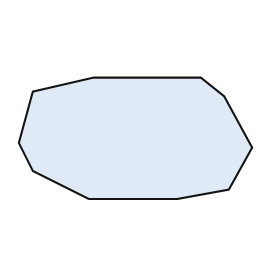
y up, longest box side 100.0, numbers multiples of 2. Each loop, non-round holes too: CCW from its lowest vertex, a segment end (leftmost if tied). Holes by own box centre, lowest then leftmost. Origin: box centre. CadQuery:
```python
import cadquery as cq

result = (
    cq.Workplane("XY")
    .moveTo(-20.0, -26.0)
    .lineTo(18.0, -26.0)
    .lineTo(40.0, -22.0)
    .lineTo(50.0, -4.0)
    .lineTo(38.0, 18.0)
    .lineTo(28.0, 26.0)
    .lineTo(-18.0, 26.0)
    .lineTo(-44.0, 20.0)
    .lineTo(-50.0, -2.0)
    .lineTo(-44.0, -14.0)
    .close()
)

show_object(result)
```